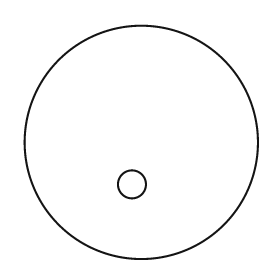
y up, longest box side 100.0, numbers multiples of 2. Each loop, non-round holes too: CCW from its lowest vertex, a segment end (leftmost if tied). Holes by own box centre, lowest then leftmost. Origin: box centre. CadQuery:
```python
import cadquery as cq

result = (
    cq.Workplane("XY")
    .moveTo(0.0, 0.0)
    .circle(50.0)
    .moveTo(-4.0, -18.0)
    .circle(6.0)
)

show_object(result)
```